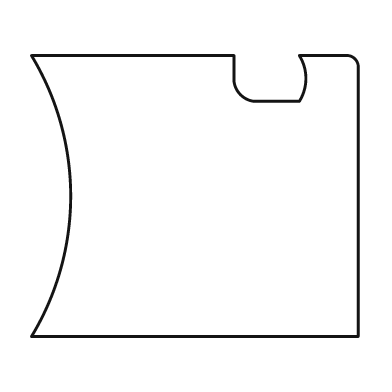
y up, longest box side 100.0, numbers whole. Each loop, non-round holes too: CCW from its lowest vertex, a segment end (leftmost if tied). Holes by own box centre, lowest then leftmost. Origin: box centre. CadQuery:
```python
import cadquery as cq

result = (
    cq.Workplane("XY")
    .moveTo(-50.0, -43.0)
    .lineTo(50.0, -43.0)
    .lineTo(50.0, 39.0)
    .threePointArc((49.0, 42.0), (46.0, 43.0))
    .lineTo(32.0, 43.0)
    .threePointArc((34.0, 36.0), (32.0, 29.0))
    .lineTo(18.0, 29.0)
    .threePointArc((14.0, 31.0), (12.0, 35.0))
    .lineTo(12.0, 43.0)
    .lineTo(-50.0, 43.0)
    .threePointArc((-38.0, 0.0), (-50.0, -43.0))
    .close()
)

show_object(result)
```